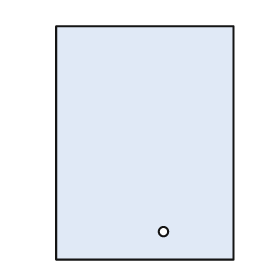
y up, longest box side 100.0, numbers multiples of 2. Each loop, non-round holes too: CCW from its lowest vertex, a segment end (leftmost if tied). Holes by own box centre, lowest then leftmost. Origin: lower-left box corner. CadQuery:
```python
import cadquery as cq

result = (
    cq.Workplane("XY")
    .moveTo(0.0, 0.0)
    .lineTo(76.0, 0.0)
    .lineTo(76.0, 100.0)
    .lineTo(0.0, 100.0)
    .close()
    .moveTo(46.0, 12.0)
    .circle(2.0)
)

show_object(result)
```